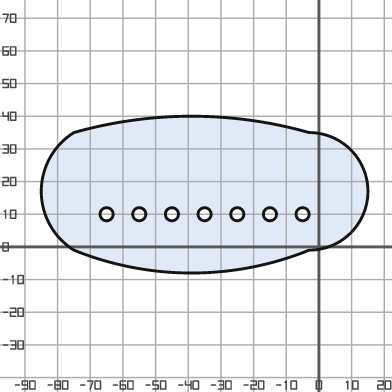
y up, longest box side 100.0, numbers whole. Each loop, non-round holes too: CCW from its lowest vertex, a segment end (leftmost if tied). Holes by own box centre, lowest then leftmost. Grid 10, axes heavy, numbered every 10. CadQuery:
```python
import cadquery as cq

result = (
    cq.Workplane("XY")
    .moveTo(-75.0, -1.0)
    .threePointArc((-39.0, -8.0), (-3.0, -1.0))
    .threePointArc((15.0, 17.0), (-3.0, 35.0))
    .threePointArc((-39.0, 40.0), (-75.0, 35.0))
    .threePointArc((-85.0, 17.0), (-75.0, -1.0))
    .close()
    .moveTo(-65.0, 10.0)
    .circle(2.0)
    .moveTo(-55.0, 10.0)
    .circle(2.0)
    .moveTo(-45.0, 10.0)
    .circle(2.0)
    .moveTo(-35.0, 10.0)
    .circle(2.0)
    .moveTo(-25.0, 10.0)
    .circle(2.0)
    .moveTo(-15.0, 10.0)
    .circle(2.0)
    .moveTo(-5.0, 10.0)
    .circle(2.0)
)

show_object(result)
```